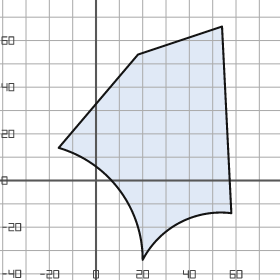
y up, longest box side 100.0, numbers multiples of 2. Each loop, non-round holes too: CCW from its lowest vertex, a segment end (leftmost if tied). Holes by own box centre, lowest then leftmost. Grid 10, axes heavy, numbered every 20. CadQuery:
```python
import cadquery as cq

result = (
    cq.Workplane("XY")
    .moveTo(20.0, -34.0)
    .threePointArc((36.0, -18.0), (58.0, -14.0))
    .lineTo(54.0, 66.0)
    .lineTo(18.0, 54.0)
    .lineTo(-16.0, 14.0)
    .threePointArc((10.0, -4.0), (20.0, -34.0))
    .close()
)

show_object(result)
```